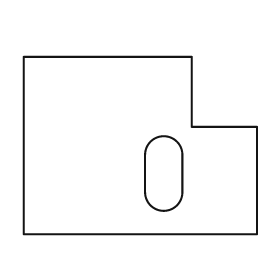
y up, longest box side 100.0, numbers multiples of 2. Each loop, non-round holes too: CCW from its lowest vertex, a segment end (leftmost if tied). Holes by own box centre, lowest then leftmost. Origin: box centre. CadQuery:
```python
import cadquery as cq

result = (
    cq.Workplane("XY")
    .moveTo(-50.0, -38.0)
    .lineTo(50.0, -38.0)
    .lineTo(50.0, 8.0)
    .lineTo(22.0, 8.0)
    .lineTo(22.0, 38.0)
    .lineTo(-50.0, 38.0)
    .close()
    .moveTo(2.0, -20.0)
    .threePointArc((10.0, -28.0), (18.0, -20.0))
    .lineTo(18.0, -4.0)
    .threePointArc((10.0, 4.0), (2.0, -4.0))
    .close()
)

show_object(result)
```